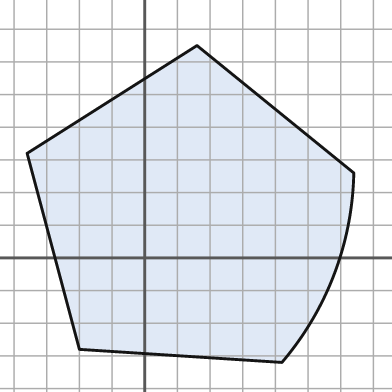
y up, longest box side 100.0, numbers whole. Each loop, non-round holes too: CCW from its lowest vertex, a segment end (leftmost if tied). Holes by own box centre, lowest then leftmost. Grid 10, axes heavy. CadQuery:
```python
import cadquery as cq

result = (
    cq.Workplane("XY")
    .moveTo(42.0, -32.0)
    .threePointArc((58.0, -5.0), (64.0, 26.0))
    .lineTo(16.0, 65.0)
    .lineTo(-36.0, 32.0)
    .lineTo(-20.0, -28.0)
    .close()
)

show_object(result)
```